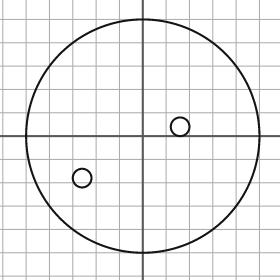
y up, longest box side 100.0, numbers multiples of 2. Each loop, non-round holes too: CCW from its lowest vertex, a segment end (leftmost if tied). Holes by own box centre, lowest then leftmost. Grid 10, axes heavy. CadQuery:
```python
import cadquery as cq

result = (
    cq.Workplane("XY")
    .moveTo(0.0, 0.0)
    .circle(50.0)
    .moveTo(-26.0, -18.0)
    .circle(4.0)
    .moveTo(16.0, 4.0)
    .circle(4.0)
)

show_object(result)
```